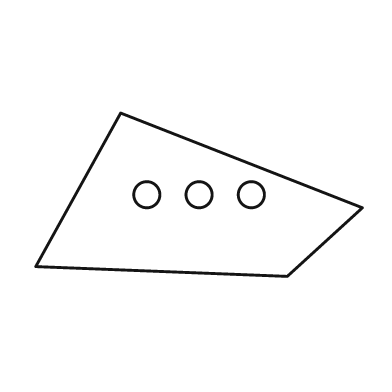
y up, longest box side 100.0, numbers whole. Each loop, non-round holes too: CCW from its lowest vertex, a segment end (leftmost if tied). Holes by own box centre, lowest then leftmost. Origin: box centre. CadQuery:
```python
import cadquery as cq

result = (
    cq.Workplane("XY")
    .moveTo(27.0, -25.0)
    .lineTo(50.0, -4.0)
    .lineTo(-24.0, 25.0)
    .lineTo(-50.0, -22.0)
    .close()
    .moveTo(-16.0, 0.0)
    .circle(4.0)
    .moveTo(0.0, 0.0)
    .circle(4.0)
    .moveTo(16.0, 0.0)
    .circle(4.0)
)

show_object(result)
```